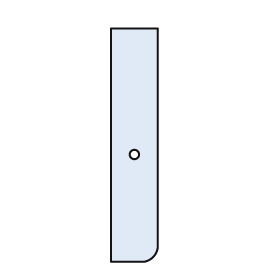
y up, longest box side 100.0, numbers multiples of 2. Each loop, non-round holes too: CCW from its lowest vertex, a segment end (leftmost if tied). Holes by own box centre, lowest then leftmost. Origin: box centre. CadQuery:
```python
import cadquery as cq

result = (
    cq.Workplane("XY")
    .moveTo(-10.0, -50.0)
    .lineTo(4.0, -50.0)
    .threePointArc((8.0, -48.0), (10.0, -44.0))
    .lineTo(10.0, 50.0)
    .lineTo(-10.0, 50.0)
    .close()
    .moveTo(0.0, -4.0)
    .circle(2.0)
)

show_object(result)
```